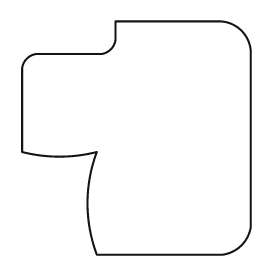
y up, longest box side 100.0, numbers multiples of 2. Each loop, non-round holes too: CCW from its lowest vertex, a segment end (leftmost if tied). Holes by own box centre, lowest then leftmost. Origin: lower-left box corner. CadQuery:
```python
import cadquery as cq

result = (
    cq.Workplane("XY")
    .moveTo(32.0, 0.0)
    .lineTo(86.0, 0.0)
    .threePointArc((94.0, 4.0), (98.0, 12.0))
    .lineTo(98.0, 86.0)
    .threePointArc((94.0, 96.0), (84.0, 100.0))
    .lineTo(40.0, 100.0)
    .lineTo(40.0, 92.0)
    .threePointArc((38.0, 88.0), (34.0, 86.0))
    .lineTo(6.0, 86.0)
    .threePointArc((2.0, 84.0), (0.0, 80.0))
    .lineTo(0.0, 44.0)
    .threePointArc((16.0, 42.0), (32.0, 44.0))
    .threePointArc((28.0, 22.0), (32.0, 0.0))
    .close()
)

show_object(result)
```